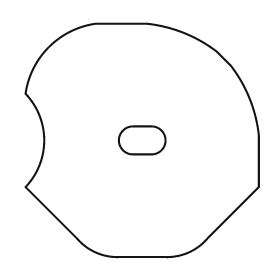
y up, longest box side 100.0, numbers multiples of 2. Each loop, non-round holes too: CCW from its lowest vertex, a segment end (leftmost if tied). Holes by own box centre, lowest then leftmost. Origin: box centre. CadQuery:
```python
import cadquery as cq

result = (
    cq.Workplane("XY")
    .moveTo(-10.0, -50.0)
    .lineTo(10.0, -50.0)
    .threePointArc((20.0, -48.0), (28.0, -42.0))
    .lineTo(50.0, -20.0)
    .lineTo(50.0, 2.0)
    .threePointArc((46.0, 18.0), (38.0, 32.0))
    .lineTo(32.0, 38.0)
    .threePointArc((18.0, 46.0), (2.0, 50.0))
    .lineTo(-20.0, 50.0)
    .threePointArc((-40.0, 40.0), (-50.0, 20.0))
    .threePointArc((-42.0, 0.0), (-50.0, -20.0))
    .lineTo(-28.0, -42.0)
    .threePointArc((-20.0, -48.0), (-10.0, -50.0))
    .close()
    .moveTo(-4.0, -6.0)
    .lineTo(4.0, -6.0)
    .threePointArc((10.0, 0.0), (4.0, 6.0))
    .lineTo(-4.0, 6.0)
    .threePointArc((-10.0, 0.0), (-4.0, -6.0))
    .close()
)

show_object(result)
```